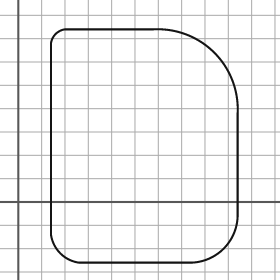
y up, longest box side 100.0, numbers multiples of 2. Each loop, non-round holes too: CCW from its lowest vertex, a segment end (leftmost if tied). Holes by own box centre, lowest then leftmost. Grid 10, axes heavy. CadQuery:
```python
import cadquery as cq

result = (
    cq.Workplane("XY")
    .moveTo(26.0, -26.0)
    .lineTo(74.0, -26.0)
    .threePointArc((88.0, -20.0), (94.0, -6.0))
    .lineTo(94.0, 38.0)
    .threePointArc((84.0, 64.0), (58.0, 74.0))
    .lineTo(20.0, 74.0)
    .threePointArc((16.0, 72.0), (14.0, 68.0))
    .lineTo(14.0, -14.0)
    .threePointArc((18.0, -22.0), (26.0, -26.0))
    .close()
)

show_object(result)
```